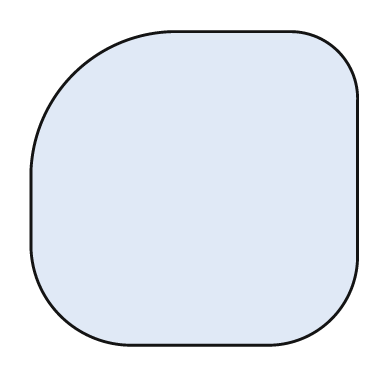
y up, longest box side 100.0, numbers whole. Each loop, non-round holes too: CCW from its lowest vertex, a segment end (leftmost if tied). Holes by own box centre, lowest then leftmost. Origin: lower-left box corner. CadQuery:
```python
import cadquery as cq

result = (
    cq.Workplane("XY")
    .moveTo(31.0, 0.0)
    .lineTo(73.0, 0.0)
    .threePointArc((92.0, 8.0), (100.0, 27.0))
    .lineTo(100.0, 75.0)
    .threePointArc((94.0, 90.0), (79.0, 96.0))
    .lineTo(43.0, 96.0)
    .threePointArc((13.0, 83.0), (0.0, 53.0))
    .lineTo(0.0, 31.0)
    .threePointArc((9.0, 9.0), (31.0, 0.0))
    .close()
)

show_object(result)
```